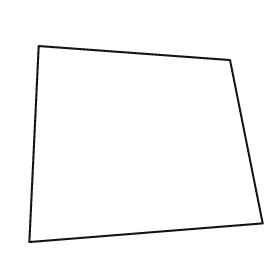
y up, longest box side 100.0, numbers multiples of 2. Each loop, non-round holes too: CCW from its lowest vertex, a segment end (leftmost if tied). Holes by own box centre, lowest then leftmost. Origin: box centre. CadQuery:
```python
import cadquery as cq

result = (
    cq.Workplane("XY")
    .moveTo(-50.0, -42.0)
    .lineTo(50.0, -34.0)
    .lineTo(36.0, 36.0)
    .lineTo(-46.0, 42.0)
    .close()
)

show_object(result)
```